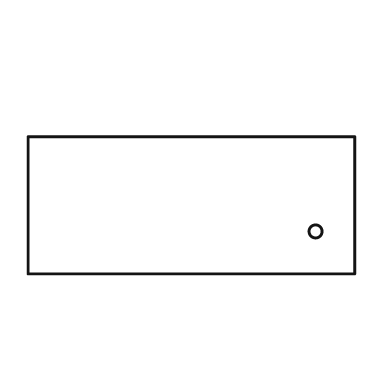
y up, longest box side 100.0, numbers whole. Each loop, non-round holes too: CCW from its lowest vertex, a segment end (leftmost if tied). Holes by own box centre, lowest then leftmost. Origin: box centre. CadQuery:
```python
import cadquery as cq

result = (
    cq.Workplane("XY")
    .moveTo(-50.0, -21.0)
    .lineTo(50.0, -21.0)
    .lineTo(50.0, 21.0)
    .lineTo(-50.0, 21.0)
    .close()
    .moveTo(38.0, -8.0)
    .circle(2.0)
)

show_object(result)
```